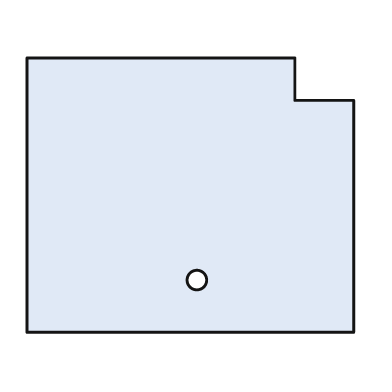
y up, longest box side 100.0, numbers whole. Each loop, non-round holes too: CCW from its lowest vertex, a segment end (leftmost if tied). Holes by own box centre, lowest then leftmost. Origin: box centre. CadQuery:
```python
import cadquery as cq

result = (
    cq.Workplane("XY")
    .moveTo(-50.0, -42.0)
    .lineTo(50.0, -42.0)
    .lineTo(50.0, 29.0)
    .lineTo(32.0, 29.0)
    .lineTo(32.0, 42.0)
    .lineTo(-50.0, 42.0)
    .close()
    .moveTo(2.0, -26.0)
    .circle(3.0)
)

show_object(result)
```